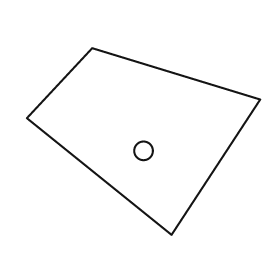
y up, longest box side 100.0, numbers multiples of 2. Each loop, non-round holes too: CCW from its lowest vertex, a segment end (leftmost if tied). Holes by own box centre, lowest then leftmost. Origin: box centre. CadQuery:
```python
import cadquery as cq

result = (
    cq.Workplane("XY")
    .moveTo(12.0, -40.0)
    .lineTo(50.0, 18.0)
    .lineTo(-22.0, 40.0)
    .lineTo(-50.0, 10.0)
    .close()
    .moveTo(0.0, -4.0)
    .circle(4.0)
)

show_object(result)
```